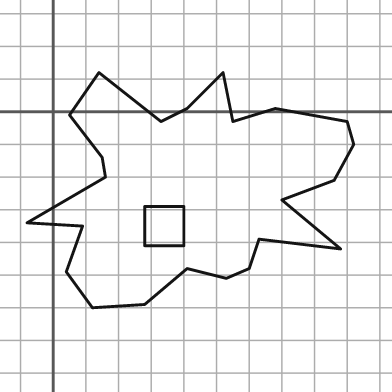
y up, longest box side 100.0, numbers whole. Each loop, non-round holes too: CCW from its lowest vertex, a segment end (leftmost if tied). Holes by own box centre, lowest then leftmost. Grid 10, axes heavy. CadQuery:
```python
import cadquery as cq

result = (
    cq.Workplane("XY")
    .moveTo(12.0, -60.0)
    .lineTo(28.0, -59.0)
    .lineTo(41.0, -48.0)
    .lineTo(53.0, -51.0)
    .lineTo(60.0, -48.0)
    .lineTo(63.0, -39.0)
    .lineTo(88.0, -42.0)
    .lineTo(70.0, -27.0)
    .lineTo(86.0, -21.0)
    .lineTo(92.0, -10.0)
    .lineTo(90.0, -3.0)
    .lineTo(68.0, 1.0)
    .lineTo(55.0, -3.0)
    .lineTo(52.0, 12.0)
    .lineTo(41.0, 1.0)
    .lineTo(33.0, -3.0)
    .lineTo(14.0, 12.0)
    .lineTo(5.0, -1.0)
    .lineTo(15.0, -14.0)
    .lineTo(16.0, -20.0)
    .lineTo(-8.0, -34.0)
    .lineTo(9.0, -35.0)
    .lineTo(4.0, -49.0)
    .close()
    .moveTo(28.0, -41.0)
    .lineTo(40.0, -41.0)
    .lineTo(40.0, -29.0)
    .lineTo(28.0, -29.0)
    .close()
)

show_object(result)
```